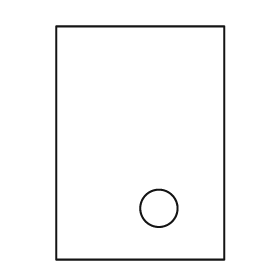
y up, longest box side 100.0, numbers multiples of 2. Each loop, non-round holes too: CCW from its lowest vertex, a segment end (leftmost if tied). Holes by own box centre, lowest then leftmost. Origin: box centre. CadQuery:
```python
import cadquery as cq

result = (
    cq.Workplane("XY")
    .moveTo(-36.0, -50.0)
    .lineTo(36.0, -50.0)
    .lineTo(36.0, 50.0)
    .lineTo(-36.0, 50.0)
    .close()
    .moveTo(8.0, -28.0)
    .circle(8.0)
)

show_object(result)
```